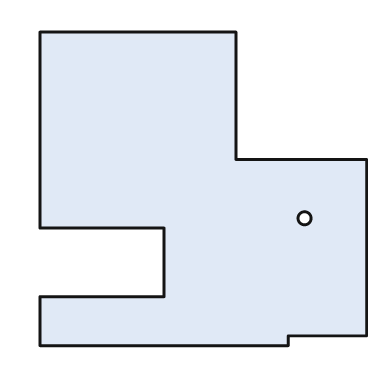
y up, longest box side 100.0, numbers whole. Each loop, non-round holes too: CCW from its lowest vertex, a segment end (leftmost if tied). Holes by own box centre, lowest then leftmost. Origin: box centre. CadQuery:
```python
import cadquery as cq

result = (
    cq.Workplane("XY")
    .moveTo(-50.0, -48.0)
    .lineTo(26.0, -48.0)
    .lineTo(26.0, -45.0)
    .lineTo(50.0, -45.0)
    .lineTo(50.0, 9.0)
    .lineTo(10.0, 9.0)
    .lineTo(10.0, 48.0)
    .lineTo(-50.0, 48.0)
    .lineTo(-50.0, -12.0)
    .lineTo(-12.0, -12.0)
    .lineTo(-12.0, -33.0)
    .lineTo(-50.0, -33.0)
    .close()
    .moveTo(31.0, -9.0)
    .circle(2.0)
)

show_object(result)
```